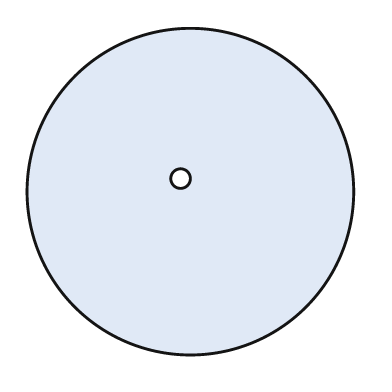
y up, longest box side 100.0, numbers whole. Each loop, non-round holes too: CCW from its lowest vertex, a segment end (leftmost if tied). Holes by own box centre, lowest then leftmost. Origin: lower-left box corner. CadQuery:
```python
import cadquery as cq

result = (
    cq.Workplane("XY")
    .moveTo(50.0, 50.0)
    .circle(50.0)
    .moveTo(47.0, 54.0)
    .circle(3.0)
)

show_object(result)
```